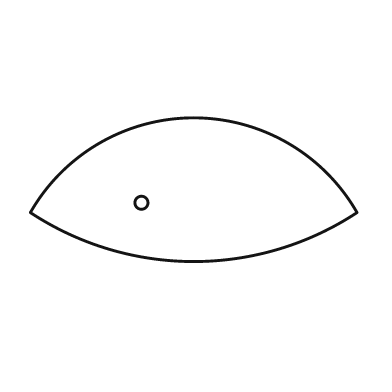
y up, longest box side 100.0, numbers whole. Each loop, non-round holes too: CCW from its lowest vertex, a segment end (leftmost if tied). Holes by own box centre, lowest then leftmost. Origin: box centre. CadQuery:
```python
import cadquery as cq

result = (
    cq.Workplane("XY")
    .moveTo(-50.0, -7.0)
    .threePointArc((0.0, -22.0), (50.0, -7.0))
    .threePointArc((0.0, 22.0), (-50.0, -7.0))
    .close()
    .moveTo(-16.0, -4.0)
    .circle(2.0)
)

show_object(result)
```